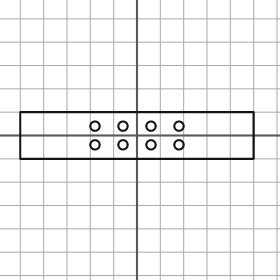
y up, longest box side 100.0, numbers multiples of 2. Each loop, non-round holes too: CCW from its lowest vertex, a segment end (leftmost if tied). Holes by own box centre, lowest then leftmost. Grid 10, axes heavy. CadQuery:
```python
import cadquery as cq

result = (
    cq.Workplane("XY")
    .moveTo(-50.0, -10.0)
    .lineTo(50.0, -10.0)
    .lineTo(50.0, 10.0)
    .lineTo(-50.0, 10.0)
    .close()
    .moveTo(-18.0, -4.0)
    .circle(2.0)
    .moveTo(-6.0, -4.0)
    .circle(2.0)
    .moveTo(6.0, -4.0)
    .circle(2.0)
    .moveTo(18.0, -4.0)
    .circle(2.0)
    .moveTo(-18.0, 4.0)
    .circle(2.0)
    .moveTo(-6.0, 4.0)
    .circle(2.0)
    .moveTo(6.0, 4.0)
    .circle(2.0)
    .moveTo(18.0, 4.0)
    .circle(2.0)
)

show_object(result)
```